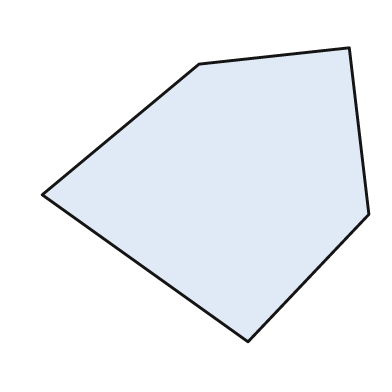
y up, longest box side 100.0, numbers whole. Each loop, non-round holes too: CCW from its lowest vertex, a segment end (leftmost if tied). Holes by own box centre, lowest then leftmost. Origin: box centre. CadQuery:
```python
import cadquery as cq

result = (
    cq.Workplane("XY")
    .moveTo(13.0, -45.0)
    .lineTo(50.0, -6.0)
    .lineTo(44.0, 45.0)
    .lineTo(-2.0, 40.0)
    .lineTo(-50.0, 0.0)
    .close()
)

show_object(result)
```